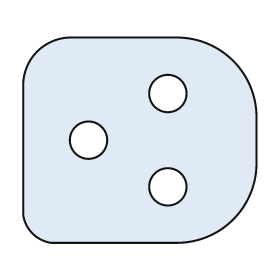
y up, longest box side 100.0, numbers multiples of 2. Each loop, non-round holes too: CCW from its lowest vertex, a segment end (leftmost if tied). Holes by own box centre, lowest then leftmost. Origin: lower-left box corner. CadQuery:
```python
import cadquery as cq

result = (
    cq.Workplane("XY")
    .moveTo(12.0, 0.0)
    .lineTo(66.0, 0.0)
    .threePointArc((90.0, 10.0), (100.0, 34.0))
    .lineTo(100.0, 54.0)
    .threePointArc((90.0, 78.0), (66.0, 88.0))
    .lineTo(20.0, 88.0)
    .threePointArc((6.0, 82.0), (0.0, 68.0))
    .lineTo(0.0, 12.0)
    .threePointArc((4.0, 4.0), (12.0, 0.0))
    .close()
    .moveTo(62.0, 24.0)
    .circle(8.0)
    .moveTo(28.0, 44.0)
    .circle(8.0)
    .moveTo(62.0, 64.0)
    .circle(8.0)
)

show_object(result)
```